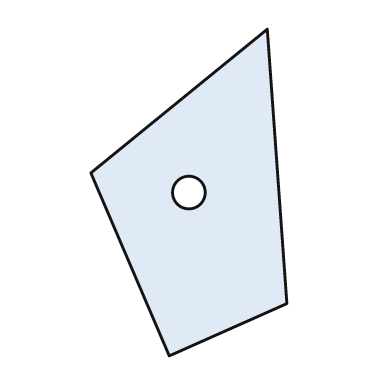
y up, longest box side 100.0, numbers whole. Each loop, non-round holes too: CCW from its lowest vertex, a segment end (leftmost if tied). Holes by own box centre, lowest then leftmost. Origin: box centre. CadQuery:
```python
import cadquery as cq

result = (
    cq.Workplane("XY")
    .moveTo(-6.0, -50.0)
    .lineTo(30.0, -34.0)
    .lineTo(24.0, 50.0)
    .lineTo(-30.0, 6.0)
    .close()
    .moveTo(0.0, 0.0)
    .circle(5.0)
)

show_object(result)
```